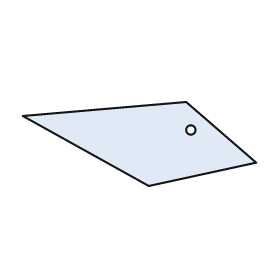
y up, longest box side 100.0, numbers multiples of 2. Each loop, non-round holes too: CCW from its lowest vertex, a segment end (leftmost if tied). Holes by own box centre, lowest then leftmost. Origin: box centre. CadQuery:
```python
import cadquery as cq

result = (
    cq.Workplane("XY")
    .moveTo(4.0, -18.0)
    .lineTo(50.0, -8.0)
    .lineTo(20.0, 18.0)
    .lineTo(-50.0, 12.0)
    .close()
    .moveTo(22.0, 6.0)
    .circle(2.0)
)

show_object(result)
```